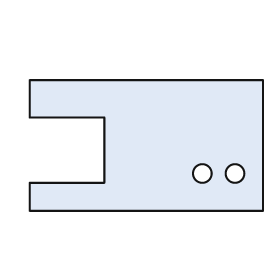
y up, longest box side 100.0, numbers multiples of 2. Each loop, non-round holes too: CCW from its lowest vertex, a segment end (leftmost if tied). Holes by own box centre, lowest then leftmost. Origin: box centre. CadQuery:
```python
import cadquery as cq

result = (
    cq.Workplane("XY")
    .moveTo(-50.0, -28.0)
    .lineTo(50.0, -28.0)
    .lineTo(50.0, 28.0)
    .lineTo(-50.0, 28.0)
    .lineTo(-50.0, 12.0)
    .lineTo(-18.0, 12.0)
    .lineTo(-18.0, -16.0)
    .lineTo(-50.0, -16.0)
    .close()
    .moveTo(24.0, -12.0)
    .circle(4.0)
    .moveTo(38.0, -12.0)
    .circle(4.0)
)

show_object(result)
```